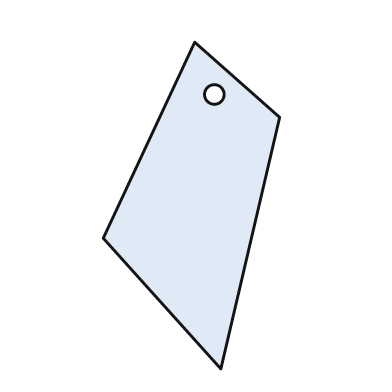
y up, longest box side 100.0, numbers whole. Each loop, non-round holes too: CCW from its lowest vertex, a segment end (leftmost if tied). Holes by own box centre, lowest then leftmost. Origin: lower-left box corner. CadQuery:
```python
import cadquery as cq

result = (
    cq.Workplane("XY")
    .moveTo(36.0, 0.0)
    .lineTo(54.0, 77.0)
    .lineTo(28.0, 100.0)
    .lineTo(0.0, 40.0)
    .close()
    .moveTo(34.0, 84.0)
    .circle(3.0)
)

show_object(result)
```